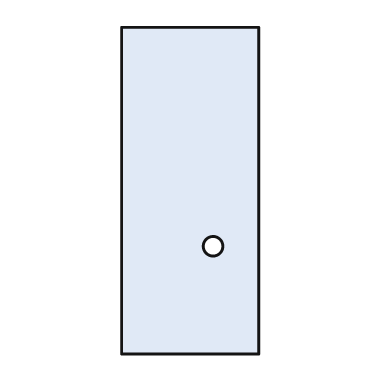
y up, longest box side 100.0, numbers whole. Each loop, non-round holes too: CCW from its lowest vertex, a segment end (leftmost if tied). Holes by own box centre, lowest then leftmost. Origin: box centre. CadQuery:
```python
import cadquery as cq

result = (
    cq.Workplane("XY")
    .moveTo(-21.0, -50.0)
    .lineTo(21.0, -50.0)
    .lineTo(21.0, 50.0)
    .lineTo(-21.0, 50.0)
    .close()
    .moveTo(7.0, -17.0)
    .circle(3.0)
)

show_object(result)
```